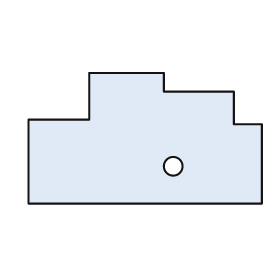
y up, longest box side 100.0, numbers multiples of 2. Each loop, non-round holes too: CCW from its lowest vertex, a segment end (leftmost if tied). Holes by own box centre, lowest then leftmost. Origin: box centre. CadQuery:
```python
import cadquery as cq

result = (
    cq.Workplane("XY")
    .moveTo(-50.0, -28.0)
    .lineTo(50.0, -28.0)
    .lineTo(50.0, 6.0)
    .lineTo(38.0, 6.0)
    .lineTo(38.0, 20.0)
    .lineTo(8.0, 20.0)
    .lineTo(8.0, 28.0)
    .lineTo(-24.0, 28.0)
    .lineTo(-24.0, 8.0)
    .lineTo(-50.0, 8.0)
    .close()
    .moveTo(12.0, -12.0)
    .circle(4.0)
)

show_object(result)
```